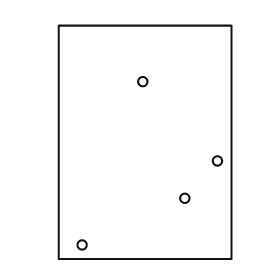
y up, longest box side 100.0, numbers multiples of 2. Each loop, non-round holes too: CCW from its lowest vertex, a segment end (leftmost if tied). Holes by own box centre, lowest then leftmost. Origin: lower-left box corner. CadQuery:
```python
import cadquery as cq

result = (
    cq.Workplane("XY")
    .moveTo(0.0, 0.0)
    .lineTo(74.0, 0.0)
    .lineTo(74.0, 100.0)
    .lineTo(0.0, 100.0)
    .close()
    .moveTo(10.0, 6.0)
    .circle(2.0)
    .moveTo(54.0, 26.0)
    .circle(2.0)
    .moveTo(68.0, 42.0)
    .circle(2.0)
    .moveTo(36.0, 76.0)
    .circle(2.0)
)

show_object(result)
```